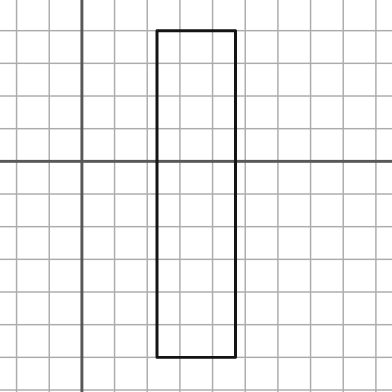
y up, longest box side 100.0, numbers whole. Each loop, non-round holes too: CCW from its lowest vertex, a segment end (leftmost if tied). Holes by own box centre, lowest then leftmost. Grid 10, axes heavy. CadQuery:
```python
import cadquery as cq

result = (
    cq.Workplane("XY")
    .moveTo(23.0, -60.0)
    .lineTo(47.0, -60.0)
    .lineTo(47.0, 40.0)
    .lineTo(23.0, 40.0)
    .close()
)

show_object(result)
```